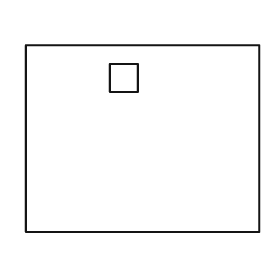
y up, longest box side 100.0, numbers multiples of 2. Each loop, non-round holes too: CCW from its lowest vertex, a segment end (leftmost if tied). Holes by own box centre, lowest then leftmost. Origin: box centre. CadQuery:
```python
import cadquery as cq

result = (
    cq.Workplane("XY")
    .moveTo(-50.0, -40.0)
    .lineTo(50.0, -40.0)
    .lineTo(50.0, 40.0)
    .lineTo(-50.0, 40.0)
    .close()
    .moveTo(-14.0, 20.0)
    .lineTo(-2.0, 20.0)
    .lineTo(-2.0, 32.0)
    .lineTo(-14.0, 32.0)
    .close()
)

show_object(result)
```